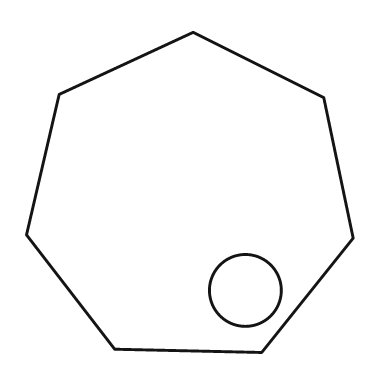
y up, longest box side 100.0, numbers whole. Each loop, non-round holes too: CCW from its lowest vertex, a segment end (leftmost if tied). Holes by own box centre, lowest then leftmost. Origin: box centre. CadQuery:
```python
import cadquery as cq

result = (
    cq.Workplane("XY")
    .moveTo(22.0, -49.0)
    .lineTo(50.0, -14.0)
    .lineTo(41.0, 29.0)
    .lineTo(1.0, 49.0)
    .lineTo(-40.0, 30.0)
    .lineTo(-50.0, -13.0)
    .lineTo(-23.0, -48.0)
    .close()
    .moveTo(17.0, -30.0)
    .circle(11.0)
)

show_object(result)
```